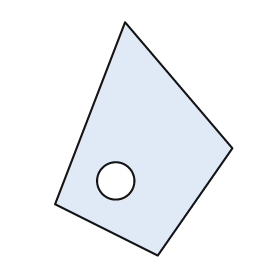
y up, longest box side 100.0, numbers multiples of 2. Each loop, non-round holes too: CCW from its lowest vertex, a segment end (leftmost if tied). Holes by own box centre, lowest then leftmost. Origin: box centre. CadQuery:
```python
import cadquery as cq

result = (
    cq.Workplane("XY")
    .moveTo(6.0, -50.0)
    .lineTo(38.0, -4.0)
    .lineTo(-8.0, 50.0)
    .lineTo(-38.0, -28.0)
    .close()
    .moveTo(-12.0, -18.0)
    .circle(8.0)
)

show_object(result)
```